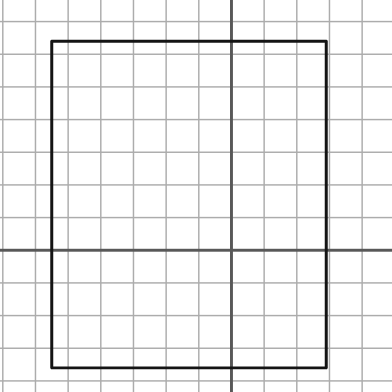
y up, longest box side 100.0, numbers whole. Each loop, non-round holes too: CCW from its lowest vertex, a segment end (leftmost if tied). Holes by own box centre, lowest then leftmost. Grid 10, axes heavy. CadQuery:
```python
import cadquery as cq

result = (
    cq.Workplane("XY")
    .moveTo(-55.0, -36.0)
    .lineTo(29.0, -36.0)
    .lineTo(29.0, 64.0)
    .lineTo(-55.0, 64.0)
    .close()
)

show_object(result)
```